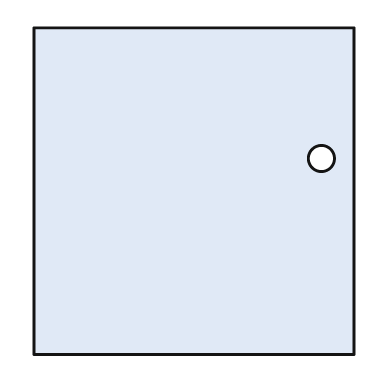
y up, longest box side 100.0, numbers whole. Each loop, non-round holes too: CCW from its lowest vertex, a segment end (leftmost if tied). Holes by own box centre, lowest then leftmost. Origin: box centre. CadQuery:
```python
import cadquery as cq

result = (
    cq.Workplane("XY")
    .moveTo(-49.0, -50.0)
    .lineTo(49.0, -50.0)
    .lineTo(49.0, 50.0)
    .lineTo(-49.0, 50.0)
    .close()
    .moveTo(39.0, 10.0)
    .circle(4.0)
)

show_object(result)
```